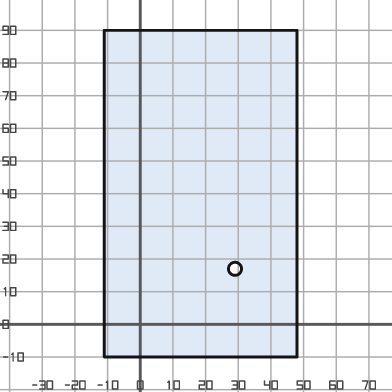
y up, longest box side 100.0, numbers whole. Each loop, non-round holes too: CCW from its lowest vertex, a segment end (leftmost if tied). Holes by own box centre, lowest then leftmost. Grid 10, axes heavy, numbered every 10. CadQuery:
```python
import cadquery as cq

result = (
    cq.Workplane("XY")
    .moveTo(-11.0, -10.0)
    .lineTo(48.0, -10.0)
    .lineTo(48.0, 90.0)
    .lineTo(-11.0, 90.0)
    .close()
    .moveTo(29.0, 17.0)
    .circle(2.0)
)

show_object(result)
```